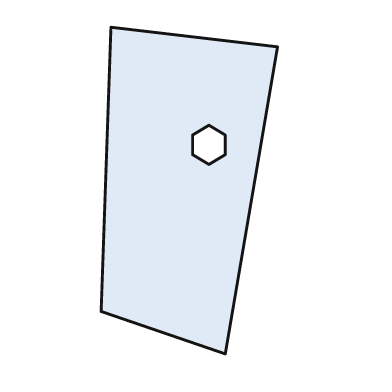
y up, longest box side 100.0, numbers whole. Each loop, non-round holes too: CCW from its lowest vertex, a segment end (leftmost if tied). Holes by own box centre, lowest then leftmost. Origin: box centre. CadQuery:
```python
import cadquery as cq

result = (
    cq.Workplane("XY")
    .moveTo(11.0, -50.0)
    .lineTo(27.0, 44.0)
    .lineTo(-24.0, 50.0)
    .lineTo(-27.0, -37.0)
    .close()
    .moveTo(6.0, 8.0)
    .lineTo(11.0, 11.0)
    .lineTo(11.0, 17.0)
    .lineTo(6.0, 20.0)
    .lineTo(1.0, 17.0)
    .lineTo(1.0, 11.0)
    .close()
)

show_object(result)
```